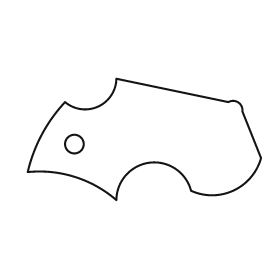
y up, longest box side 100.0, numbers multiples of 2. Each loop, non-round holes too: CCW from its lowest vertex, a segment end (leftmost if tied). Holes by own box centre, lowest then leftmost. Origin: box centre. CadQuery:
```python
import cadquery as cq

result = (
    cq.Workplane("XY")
    .moveTo(-12.0, -26.0)
    .threePointArc((2.0, -10.0), (20.0, -22.0))
    .threePointArc((38.0, -22.0), (50.0, -8.0))
    .lineTo(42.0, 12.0)
    .threePointArc((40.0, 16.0), (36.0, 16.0))
    .lineTo(-12.0, 26.0)
    .threePointArc((-20.0, 14.0), (-34.0, 16.0))
    .threePointArc((-44.0, 2.0), (-50.0, -14.0))
    .threePointArc((-30.0, -16.0), (-12.0, -26.0))
    .close()
    .moveTo(-30.0, -2.0)
    .circle(4.0)
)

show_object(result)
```